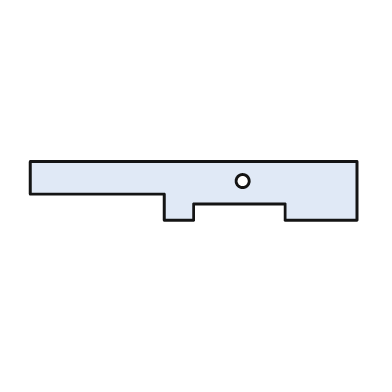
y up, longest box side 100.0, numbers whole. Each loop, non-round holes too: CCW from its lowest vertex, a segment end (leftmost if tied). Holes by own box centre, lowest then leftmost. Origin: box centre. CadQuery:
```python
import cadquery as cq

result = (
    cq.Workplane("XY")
    .moveTo(-9.0, -9.0)
    .lineTo(0.0, -9.0)
    .lineTo(0.0, -4.0)
    .lineTo(28.0, -4.0)
    .lineTo(28.0, -9.0)
    .lineTo(50.0, -9.0)
    .lineTo(50.0, 9.0)
    .lineTo(-50.0, 9.0)
    .lineTo(-50.0, -1.0)
    .lineTo(-9.0, -1.0)
    .close()
    .moveTo(15.0, 3.0)
    .circle(2.0)
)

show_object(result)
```